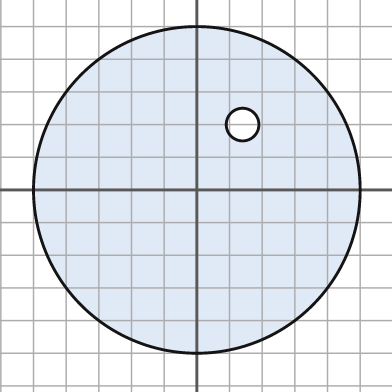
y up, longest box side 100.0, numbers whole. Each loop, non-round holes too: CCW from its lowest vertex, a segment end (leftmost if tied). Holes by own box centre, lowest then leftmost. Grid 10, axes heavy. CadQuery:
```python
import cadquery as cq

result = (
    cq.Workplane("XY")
    .moveTo(0.0, 0.0)
    .circle(50.0)
    .moveTo(14.0, 20.0)
    .circle(5.0)
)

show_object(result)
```